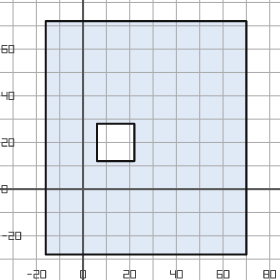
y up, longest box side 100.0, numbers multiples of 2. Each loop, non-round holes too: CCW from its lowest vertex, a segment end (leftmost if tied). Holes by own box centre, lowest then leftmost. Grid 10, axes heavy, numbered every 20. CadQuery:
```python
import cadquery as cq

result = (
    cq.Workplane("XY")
    .moveTo(-16.0, -28.0)
    .lineTo(70.0, -28.0)
    .lineTo(70.0, 72.0)
    .lineTo(-16.0, 72.0)
    .close()
    .moveTo(6.0, 12.0)
    .lineTo(22.0, 12.0)
    .lineTo(22.0, 28.0)
    .lineTo(6.0, 28.0)
    .close()
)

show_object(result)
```